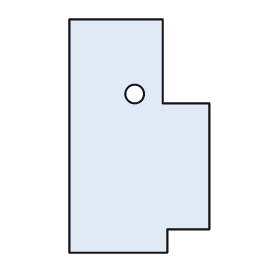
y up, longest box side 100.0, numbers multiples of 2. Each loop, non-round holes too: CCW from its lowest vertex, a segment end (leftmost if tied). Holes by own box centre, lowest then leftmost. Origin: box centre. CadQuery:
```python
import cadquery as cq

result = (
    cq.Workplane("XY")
    .moveTo(-30.0, -50.0)
    .lineTo(12.0, -50.0)
    .lineTo(12.0, -40.0)
    .lineTo(30.0, -40.0)
    .lineTo(30.0, 14.0)
    .lineTo(10.0, 14.0)
    .lineTo(10.0, 50.0)
    .lineTo(-30.0, 50.0)
    .close()
    .moveTo(-2.0, 18.0)
    .circle(4.0)
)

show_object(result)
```